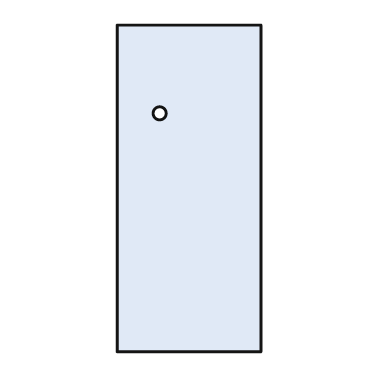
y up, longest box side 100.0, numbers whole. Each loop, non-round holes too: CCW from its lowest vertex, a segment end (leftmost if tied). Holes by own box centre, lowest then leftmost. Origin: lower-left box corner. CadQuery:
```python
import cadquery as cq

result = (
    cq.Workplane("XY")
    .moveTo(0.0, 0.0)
    .lineTo(44.0, 0.0)
    .lineTo(44.0, 100.0)
    .lineTo(0.0, 100.0)
    .close()
    .moveTo(13.0, 73.0)
    .circle(2.0)
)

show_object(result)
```